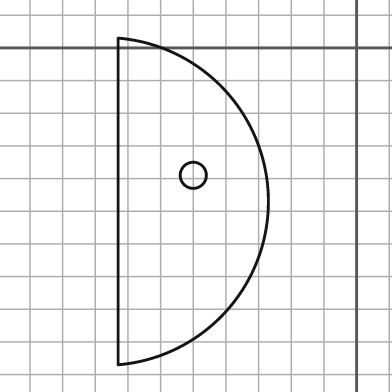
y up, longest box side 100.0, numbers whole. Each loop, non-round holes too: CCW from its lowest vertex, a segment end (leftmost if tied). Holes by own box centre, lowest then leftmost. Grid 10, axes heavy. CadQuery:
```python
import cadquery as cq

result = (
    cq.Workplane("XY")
    .moveTo(-73.0, -97.0)
    .threePointArc((-27.0, -47.0), (-73.0, 3.0))
    .close()
    .moveTo(-50.0, -39.0)
    .circle(4.0)
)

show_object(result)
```